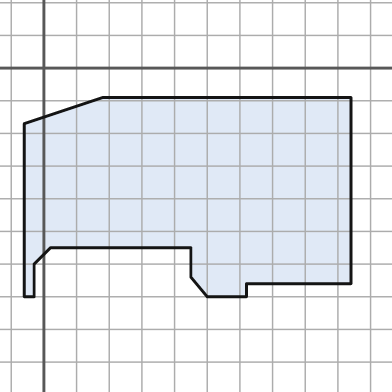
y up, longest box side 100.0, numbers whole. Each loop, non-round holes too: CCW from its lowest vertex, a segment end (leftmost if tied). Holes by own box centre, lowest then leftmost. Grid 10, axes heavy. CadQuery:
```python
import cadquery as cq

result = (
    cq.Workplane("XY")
    .moveTo(-6.0, -70.0)
    .lineTo(-3.0, -70.0)
    .lineTo(-3.0, -60.0)
    .lineTo(2.0, -55.0)
    .lineTo(45.0, -55.0)
    .lineTo(45.0, -64.0)
    .lineTo(50.0, -70.0)
    .lineTo(62.0, -70.0)
    .lineTo(62.0, -66.0)
    .lineTo(94.0, -66.0)
    .lineTo(94.0, -9.0)
    .lineTo(18.0, -9.0)
    .lineTo(-6.0, -17.0)
    .close()
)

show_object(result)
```